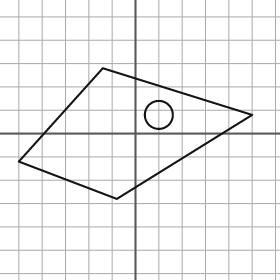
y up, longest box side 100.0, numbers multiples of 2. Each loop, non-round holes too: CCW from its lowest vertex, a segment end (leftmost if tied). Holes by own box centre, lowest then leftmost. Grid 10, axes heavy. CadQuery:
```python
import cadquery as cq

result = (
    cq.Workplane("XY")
    .moveTo(-8.0, -28.0)
    .lineTo(50.0, 8.0)
    .lineTo(-14.0, 28.0)
    .lineTo(-50.0, -12.0)
    .close()
    .moveTo(10.0, 8.0)
    .circle(6.0)
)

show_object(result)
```